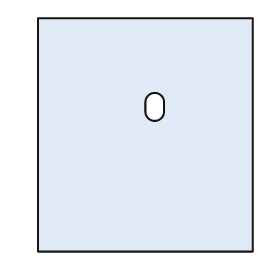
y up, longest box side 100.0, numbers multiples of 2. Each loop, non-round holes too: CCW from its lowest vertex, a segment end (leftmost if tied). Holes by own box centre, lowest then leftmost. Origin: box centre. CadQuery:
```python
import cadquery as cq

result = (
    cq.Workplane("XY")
    .moveTo(-46.0, -50.0)
    .lineTo(46.0, -50.0)
    .lineTo(46.0, 50.0)
    .lineTo(-46.0, 50.0)
    .close()
    .moveTo(0.0, 10.0)
    .threePointArc((4.0, 6.0), (8.0, 10.0))
    .lineTo(8.0, 14.0)
    .threePointArc((4.0, 18.0), (0.0, 14.0))
    .close()
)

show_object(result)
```